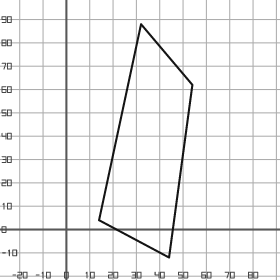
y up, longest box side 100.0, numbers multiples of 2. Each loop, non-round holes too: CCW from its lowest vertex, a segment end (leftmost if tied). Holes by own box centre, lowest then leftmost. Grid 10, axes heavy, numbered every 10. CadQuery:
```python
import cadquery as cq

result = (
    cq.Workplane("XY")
    .moveTo(44.0, -12.0)
    .lineTo(54.0, 62.0)
    .lineTo(32.0, 88.0)
    .lineTo(14.0, 4.0)
    .close()
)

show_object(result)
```